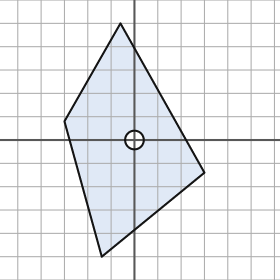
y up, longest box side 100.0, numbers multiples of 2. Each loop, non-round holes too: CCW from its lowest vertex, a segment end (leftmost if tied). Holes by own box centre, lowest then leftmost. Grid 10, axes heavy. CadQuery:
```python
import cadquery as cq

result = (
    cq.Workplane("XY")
    .moveTo(-14.0, -50.0)
    .lineTo(30.0, -14.0)
    .lineTo(-6.0, 50.0)
    .lineTo(-30.0, 8.0)
    .close()
    .moveTo(0.0, 0.0)
    .circle(4.0)
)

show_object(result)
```